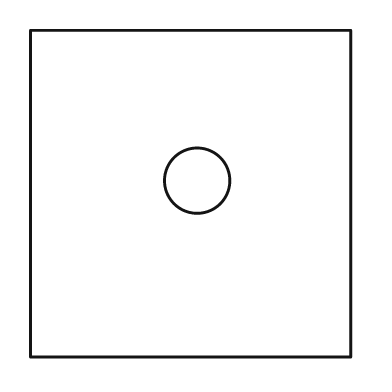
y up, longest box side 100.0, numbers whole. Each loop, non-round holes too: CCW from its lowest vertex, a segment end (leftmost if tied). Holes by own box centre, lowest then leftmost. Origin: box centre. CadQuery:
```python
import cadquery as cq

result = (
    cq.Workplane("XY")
    .moveTo(-49.0, -50.0)
    .lineTo(49.0, -50.0)
    .lineTo(49.0, 50.0)
    .lineTo(-49.0, 50.0)
    .close()
    .moveTo(2.0, 4.0)
    .circle(10.0)
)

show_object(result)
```